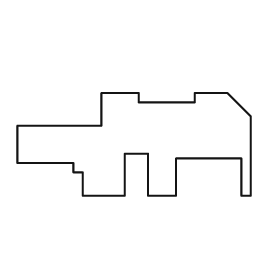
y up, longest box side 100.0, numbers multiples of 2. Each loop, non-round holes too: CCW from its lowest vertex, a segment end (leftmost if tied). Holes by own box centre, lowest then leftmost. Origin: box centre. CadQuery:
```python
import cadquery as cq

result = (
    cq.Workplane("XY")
    .moveTo(-22.0, -22.0)
    .lineTo(-4.0, -22.0)
    .lineTo(-4.0, -4.0)
    .lineTo(6.0, -4.0)
    .lineTo(6.0, -22.0)
    .lineTo(18.0, -22.0)
    .lineTo(18.0, -6.0)
    .lineTo(46.0, -6.0)
    .lineTo(46.0, -22.0)
    .lineTo(50.0, -22.0)
    .lineTo(50.0, 12.0)
    .lineTo(40.0, 22.0)
    .lineTo(26.0, 22.0)
    .lineTo(26.0, 18.0)
    .lineTo(2.0, 18.0)
    .lineTo(2.0, 22.0)
    .lineTo(-14.0, 22.0)
    .lineTo(-14.0, 8.0)
    .lineTo(-50.0, 8.0)
    .lineTo(-50.0, -8.0)
    .lineTo(-26.0, -8.0)
    .lineTo(-26.0, -12.0)
    .lineTo(-22.0, -12.0)
    .close()
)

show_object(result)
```